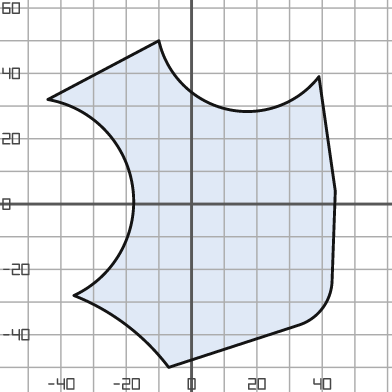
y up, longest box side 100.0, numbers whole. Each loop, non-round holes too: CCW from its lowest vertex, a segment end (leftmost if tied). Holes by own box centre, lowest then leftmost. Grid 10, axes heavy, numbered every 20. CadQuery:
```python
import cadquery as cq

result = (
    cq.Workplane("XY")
    .moveTo(-7.0, -50.0)
    .lineTo(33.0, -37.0)
    .threePointArc((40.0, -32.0), (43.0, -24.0))
    .lineTo(44.0, 4.0)
    .lineTo(39.0, 39.0)
    .threePointArc((11.0, 29.0), (-10.0, 50.0))
    .lineTo(-44.0, 32.0)
    .threePointArc((-18.0, 5.0), (-36.0, -28.0))
    .threePointArc((-20.0, -37.0), (-7.0, -50.0))
    .close()
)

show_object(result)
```